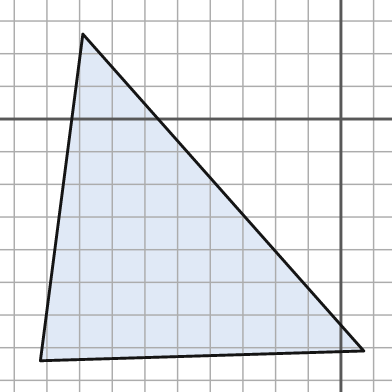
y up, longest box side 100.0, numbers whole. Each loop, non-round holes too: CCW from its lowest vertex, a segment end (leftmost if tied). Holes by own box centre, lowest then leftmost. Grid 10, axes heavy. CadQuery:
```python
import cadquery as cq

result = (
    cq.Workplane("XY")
    .moveTo(-92.0, -74.0)
    .lineTo(7.0, -71.0)
    .lineTo(-79.0, 26.0)
    .close()
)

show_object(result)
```